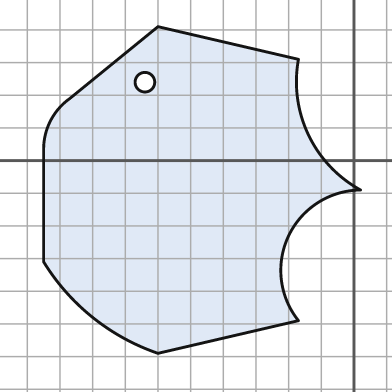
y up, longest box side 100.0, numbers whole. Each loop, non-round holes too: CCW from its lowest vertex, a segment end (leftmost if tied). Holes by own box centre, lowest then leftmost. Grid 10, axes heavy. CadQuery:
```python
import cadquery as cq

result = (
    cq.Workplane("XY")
    .moveTo(-60.0, -59.0)
    .lineTo(-17.0, -49.0)
    .threePointArc((-20.0, -23.0), (2.0, -9.0))
    .threePointArc((-14.0, 8.0), (-17.0, 31.0))
    .lineTo(-60.0, 41.0)
    .lineTo(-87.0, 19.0)
    .threePointArc((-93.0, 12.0), (-95.0, 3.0))
    .lineTo(-95.0, -31.0)
    .threePointArc((-80.0, -48.0), (-60.0, -59.0))
    .close()
    .moveTo(-64.0, 24.0)
    .circle(3.0)
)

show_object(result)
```